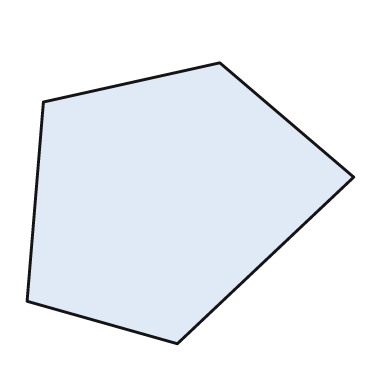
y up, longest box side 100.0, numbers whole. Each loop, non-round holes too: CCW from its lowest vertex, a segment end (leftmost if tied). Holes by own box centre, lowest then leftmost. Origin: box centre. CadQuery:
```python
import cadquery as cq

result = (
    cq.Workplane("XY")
    .moveTo(-4.0, -43.0)
    .lineTo(50.0, 8.0)
    .lineTo(9.0, 43.0)
    .lineTo(-45.0, 31.0)
    .lineTo(-50.0, -30.0)
    .close()
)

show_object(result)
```